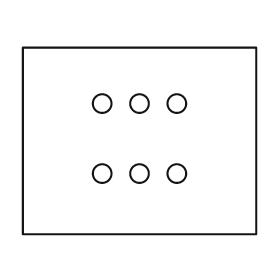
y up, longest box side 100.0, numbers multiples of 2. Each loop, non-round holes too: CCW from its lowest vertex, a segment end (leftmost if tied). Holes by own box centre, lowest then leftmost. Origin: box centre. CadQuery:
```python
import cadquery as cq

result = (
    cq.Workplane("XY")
    .moveTo(-50.0, -40.0)
    .lineTo(50.0, -40.0)
    .lineTo(50.0, 40.0)
    .lineTo(-50.0, 40.0)
    .close()
    .moveTo(-16.0, -14.0)
    .circle(4.0)
    .moveTo(0.0, -14.0)
    .circle(4.0)
    .moveTo(16.0, -14.0)
    .circle(4.0)
    .moveTo(-16.0, 16.0)
    .circle(4.0)
    .moveTo(0.0, 16.0)
    .circle(4.0)
    .moveTo(16.0, 16.0)
    .circle(4.0)
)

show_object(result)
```